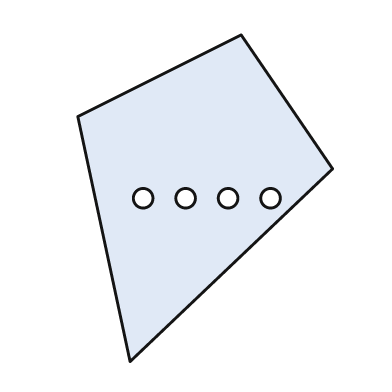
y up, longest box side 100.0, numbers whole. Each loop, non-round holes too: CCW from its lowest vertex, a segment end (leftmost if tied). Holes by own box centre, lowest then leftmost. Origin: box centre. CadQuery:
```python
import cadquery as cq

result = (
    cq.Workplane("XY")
    .moveTo(-23.0, -50.0)
    .lineTo(39.0, 9.0)
    .lineTo(11.0, 50.0)
    .lineTo(-39.0, 25.0)
    .close()
    .moveTo(-19.0, 0.0)
    .circle(3.0)
    .moveTo(-6.0, 0.0)
    .circle(3.0)
    .moveTo(7.0, 0.0)
    .circle(3.0)
    .moveTo(20.0, 0.0)
    .circle(3.0)
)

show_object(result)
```